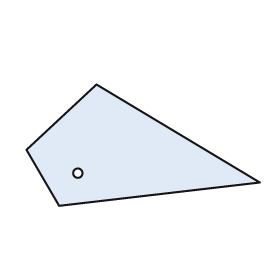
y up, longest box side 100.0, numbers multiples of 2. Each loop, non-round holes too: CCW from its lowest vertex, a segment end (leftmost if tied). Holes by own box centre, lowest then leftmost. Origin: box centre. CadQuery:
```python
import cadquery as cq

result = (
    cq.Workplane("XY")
    .moveTo(-36.0, -26.0)
    .lineTo(50.0, -16.0)
    .lineTo(-20.0, 26.0)
    .lineTo(-50.0, -2.0)
    .close()
    .moveTo(-28.0, -12.0)
    .circle(2.0)
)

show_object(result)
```